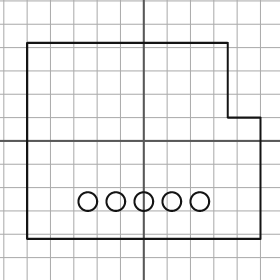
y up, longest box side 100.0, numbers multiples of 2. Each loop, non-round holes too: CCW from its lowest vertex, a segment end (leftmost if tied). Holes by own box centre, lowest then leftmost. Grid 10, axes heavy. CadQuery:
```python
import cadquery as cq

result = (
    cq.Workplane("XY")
    .moveTo(-50.0, -42.0)
    .lineTo(50.0, -42.0)
    .lineTo(50.0, 10.0)
    .lineTo(36.0, 10.0)
    .lineTo(36.0, 42.0)
    .lineTo(-50.0, 42.0)
    .close()
    .moveTo(-24.0, -26.0)
    .circle(4.0)
    .moveTo(-12.0, -26.0)
    .circle(4.0)
    .moveTo(0.0, -26.0)
    .circle(4.0)
    .moveTo(12.0, -26.0)
    .circle(4.0)
    .moveTo(24.0, -26.0)
    .circle(4.0)
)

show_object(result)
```